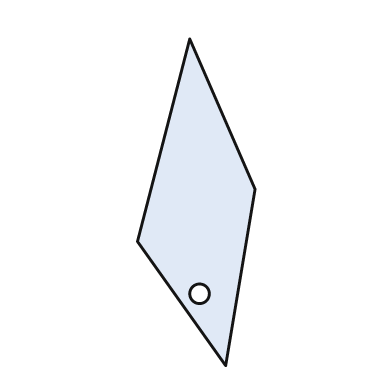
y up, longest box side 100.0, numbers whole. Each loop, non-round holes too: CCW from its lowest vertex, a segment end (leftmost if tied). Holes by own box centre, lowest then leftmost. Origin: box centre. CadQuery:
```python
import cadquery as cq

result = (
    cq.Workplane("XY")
    .moveTo(9.0, -50.0)
    .lineTo(18.0, 4.0)
    .lineTo(-2.0, 50.0)
    .lineTo(-18.0, -12.0)
    .close()
    .moveTo(1.0, -28.0)
    .circle(3.0)
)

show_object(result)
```